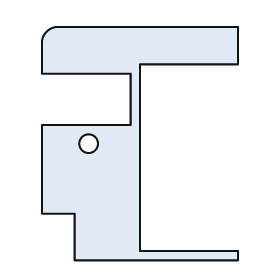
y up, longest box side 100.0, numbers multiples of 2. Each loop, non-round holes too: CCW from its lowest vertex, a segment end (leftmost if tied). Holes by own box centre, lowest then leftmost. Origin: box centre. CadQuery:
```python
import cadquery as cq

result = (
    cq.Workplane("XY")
    .moveTo(-28.0, -50.0)
    .lineTo(42.0, -50.0)
    .lineTo(42.0, -46.0)
    .lineTo(0.0, -46.0)
    .lineTo(0.0, 34.0)
    .lineTo(42.0, 34.0)
    .lineTo(42.0, 50.0)
    .lineTo(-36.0, 50.0)
    .threePointArc((-40.0, 48.0), (-42.0, 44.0))
    .lineTo(-42.0, 30.0)
    .lineTo(-4.0, 30.0)
    .lineTo(-4.0, 8.0)
    .lineTo(-42.0, 8.0)
    .lineTo(-42.0, -30.0)
    .lineTo(-28.0, -30.0)
    .close()
    .moveTo(-22.0, 0.0)
    .circle(4.0)
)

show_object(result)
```